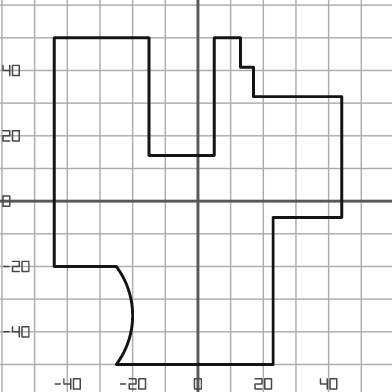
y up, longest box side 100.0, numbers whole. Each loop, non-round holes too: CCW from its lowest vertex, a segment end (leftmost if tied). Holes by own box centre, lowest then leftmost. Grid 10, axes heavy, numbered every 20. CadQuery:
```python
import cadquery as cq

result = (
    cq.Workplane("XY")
    .moveTo(-25.0, -50.0)
    .lineTo(23.0, -50.0)
    .lineTo(23.0, -5.0)
    .lineTo(44.0, -5.0)
    .lineTo(44.0, 32.0)
    .lineTo(17.0, 32.0)
    .lineTo(17.0, 41.0)
    .lineTo(13.0, 41.0)
    .lineTo(13.0, 50.0)
    .lineTo(5.0, 50.0)
    .lineTo(5.0, 14.0)
    .lineTo(-15.0, 14.0)
    .lineTo(-15.0, 50.0)
    .lineTo(-44.0, 50.0)
    .lineTo(-44.0, -20.0)
    .lineTo(-25.0, -20.0)
    .threePointArc((-20.0, -35.0), (-25.0, -50.0))
    .close()
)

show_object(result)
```